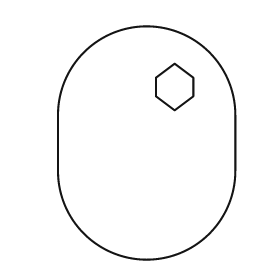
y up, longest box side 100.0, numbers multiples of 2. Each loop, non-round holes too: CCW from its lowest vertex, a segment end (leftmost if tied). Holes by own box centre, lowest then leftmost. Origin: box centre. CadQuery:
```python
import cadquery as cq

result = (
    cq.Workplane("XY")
    .moveTo(-38.0, -12.0)
    .threePointArc((0.0, -50.0), (38.0, -12.0))
    .lineTo(38.0, 12.0)
    .threePointArc((0.0, 50.0), (-38.0, 12.0))
    .close()
    .moveTo(12.0, 14.0)
    .lineTo(20.0, 20.0)
    .lineTo(20.0, 28.0)
    .lineTo(12.0, 34.0)
    .lineTo(4.0, 28.0)
    .lineTo(4.0, 20.0)
    .close()
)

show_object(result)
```